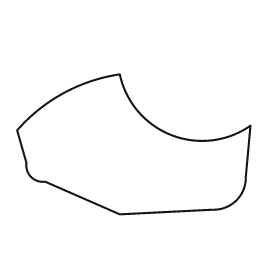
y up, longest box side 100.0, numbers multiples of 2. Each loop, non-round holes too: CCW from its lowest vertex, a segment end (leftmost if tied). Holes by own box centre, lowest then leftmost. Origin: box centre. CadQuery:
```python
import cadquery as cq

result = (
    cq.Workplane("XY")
    .moveTo(-6.0, -30.0)
    .lineTo(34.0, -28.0)
    .threePointArc((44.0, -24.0), (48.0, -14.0))
    .lineTo(50.0, 8.0)
    .threePointArc((16.0, 4.0), (-6.0, 30.0))
    .threePointArc((-30.0, 22.0), (-50.0, 6.0))
    .lineTo(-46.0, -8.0)
    .threePointArc((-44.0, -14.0), (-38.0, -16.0))
    .close()
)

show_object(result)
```